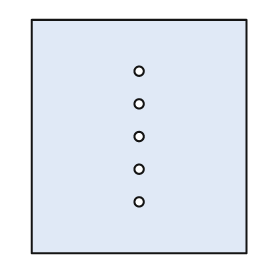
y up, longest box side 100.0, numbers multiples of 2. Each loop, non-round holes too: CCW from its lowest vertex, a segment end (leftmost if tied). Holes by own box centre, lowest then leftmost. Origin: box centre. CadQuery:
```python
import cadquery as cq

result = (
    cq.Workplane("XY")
    .moveTo(-46.0, -50.0)
    .lineTo(46.0, -50.0)
    .lineTo(46.0, 50.0)
    .lineTo(-46.0, 50.0)
    .close()
    .moveTo(0.0, -28.0)
    .circle(2.0)
    .moveTo(0.0, -14.0)
    .circle(2.0)
    .moveTo(0.0, 0.0)
    .circle(2.0)
    .moveTo(0.0, 14.0)
    .circle(2.0)
    .moveTo(0.0, 28.0)
    .circle(2.0)
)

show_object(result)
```